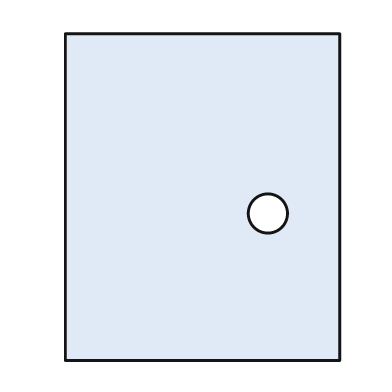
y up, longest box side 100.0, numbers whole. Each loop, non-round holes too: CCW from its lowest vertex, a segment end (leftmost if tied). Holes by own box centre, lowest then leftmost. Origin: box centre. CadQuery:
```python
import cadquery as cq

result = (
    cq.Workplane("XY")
    .moveTo(-42.0, -50.0)
    .lineTo(42.0, -50.0)
    .lineTo(42.0, 50.0)
    .lineTo(-42.0, 50.0)
    .close()
    .moveTo(20.0, -5.0)
    .circle(6.0)
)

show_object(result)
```